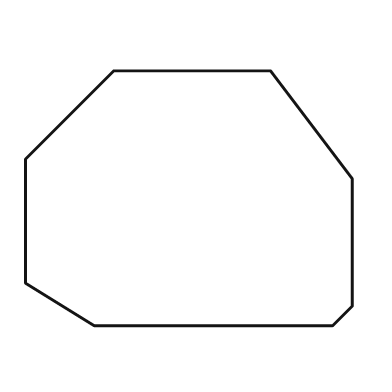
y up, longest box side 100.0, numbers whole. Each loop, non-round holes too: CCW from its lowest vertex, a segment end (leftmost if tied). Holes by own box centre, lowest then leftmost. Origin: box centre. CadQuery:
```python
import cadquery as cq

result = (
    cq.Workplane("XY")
    .moveTo(-29.0, -39.0)
    .lineTo(44.0, -39.0)
    .lineTo(50.0, -33.0)
    .lineTo(50.0, 6.0)
    .lineTo(25.0, 39.0)
    .lineTo(-23.0, 39.0)
    .lineTo(-50.0, 12.0)
    .lineTo(-50.0, -26.0)
    .close()
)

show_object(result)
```